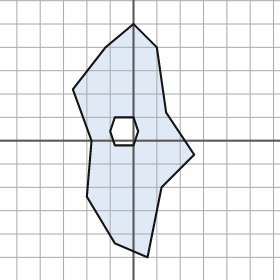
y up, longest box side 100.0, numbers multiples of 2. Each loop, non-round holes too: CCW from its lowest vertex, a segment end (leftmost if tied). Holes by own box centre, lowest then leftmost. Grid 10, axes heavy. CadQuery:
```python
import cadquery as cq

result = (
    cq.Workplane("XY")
    .moveTo(6.0, -50.0)
    .lineTo(12.0, -20.0)
    .lineTo(26.0, -6.0)
    .lineTo(14.0, 12.0)
    .lineTo(10.0, 40.0)
    .lineTo(0.0, 50.0)
    .lineTo(-12.0, 40.0)
    .lineTo(-26.0, 22.0)
    .lineTo(-18.0, 0.0)
    .lineTo(-20.0, -24.0)
    .lineTo(-8.0, -44.0)
    .close()
    .moveTo(-8.0, -2.0)
    .lineTo(0.0, -2.0)
    .lineTo(2.0, 4.0)
    .lineTo(0.0, 10.0)
    .lineTo(-8.0, 10.0)
    .lineTo(-10.0, 4.0)
    .close()
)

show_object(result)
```